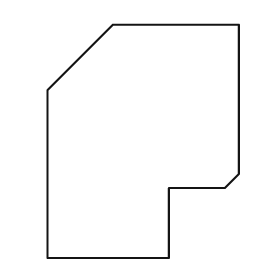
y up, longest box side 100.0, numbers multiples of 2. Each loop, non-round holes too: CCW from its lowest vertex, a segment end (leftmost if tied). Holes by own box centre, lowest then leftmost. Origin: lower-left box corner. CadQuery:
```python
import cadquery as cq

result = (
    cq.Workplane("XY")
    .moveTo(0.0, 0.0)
    .lineTo(52.0, 0.0)
    .lineTo(52.0, 30.0)
    .lineTo(76.0, 30.0)
    .lineTo(82.0, 36.0)
    .lineTo(82.0, 100.0)
    .lineTo(28.0, 100.0)
    .lineTo(0.0, 72.0)
    .close()
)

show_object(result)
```